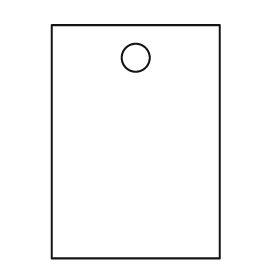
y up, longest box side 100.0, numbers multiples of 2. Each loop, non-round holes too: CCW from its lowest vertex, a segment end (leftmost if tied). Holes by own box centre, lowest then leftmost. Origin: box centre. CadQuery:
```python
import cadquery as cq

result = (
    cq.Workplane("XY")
    .moveTo(-36.0, -50.0)
    .lineTo(36.0, -50.0)
    .lineTo(36.0, 50.0)
    .lineTo(-36.0, 50.0)
    .close()
    .moveTo(0.0, 36.0)
    .circle(6.0)
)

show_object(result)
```